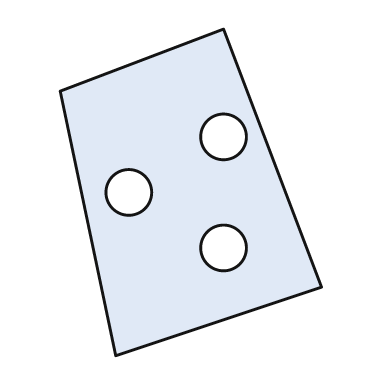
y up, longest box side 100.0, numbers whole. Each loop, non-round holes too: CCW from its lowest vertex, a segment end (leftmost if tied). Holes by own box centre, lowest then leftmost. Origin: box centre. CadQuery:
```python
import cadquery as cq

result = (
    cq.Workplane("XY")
    .moveTo(-23.0, -50.0)
    .lineTo(40.0, -29.0)
    .lineTo(10.0, 50.0)
    .lineTo(-40.0, 31.0)
    .close()
    .moveTo(10.0, -17.0)
    .circle(7.0)
    .moveTo(-19.0, 0.0)
    .circle(7.0)
    .moveTo(10.0, 17.0)
    .circle(7.0)
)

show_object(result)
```